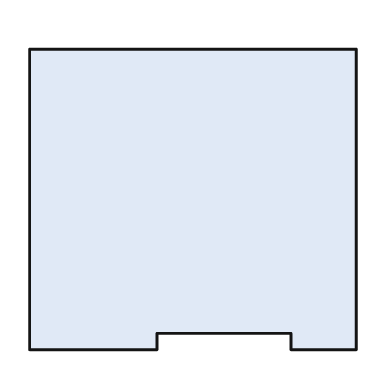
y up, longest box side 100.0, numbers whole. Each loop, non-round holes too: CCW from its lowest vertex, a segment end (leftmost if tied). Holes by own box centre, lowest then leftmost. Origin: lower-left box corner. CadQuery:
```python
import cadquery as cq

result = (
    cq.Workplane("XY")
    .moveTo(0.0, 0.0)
    .lineTo(39.0, 0.0)
    .lineTo(39.0, 5.0)
    .lineTo(80.0, 5.0)
    .lineTo(80.0, 0.0)
    .lineTo(100.0, 0.0)
    .lineTo(100.0, 92.0)
    .lineTo(0.0, 92.0)
    .close()
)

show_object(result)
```